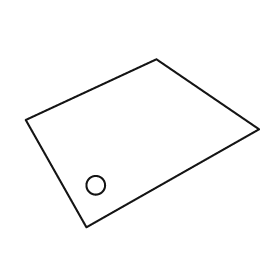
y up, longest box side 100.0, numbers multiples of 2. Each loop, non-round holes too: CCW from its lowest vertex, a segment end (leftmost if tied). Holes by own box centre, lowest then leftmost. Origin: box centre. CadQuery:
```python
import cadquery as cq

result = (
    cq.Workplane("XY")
    .moveTo(-24.0, -36.0)
    .lineTo(50.0, 6.0)
    .lineTo(6.0, 36.0)
    .lineTo(-50.0, 10.0)
    .close()
    .moveTo(-20.0, -18.0)
    .circle(4.0)
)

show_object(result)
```